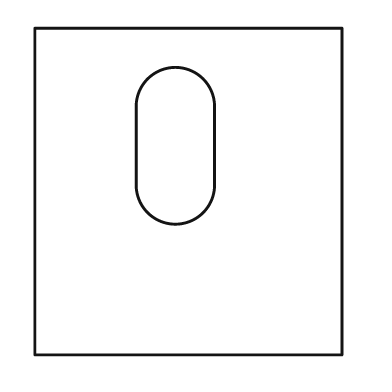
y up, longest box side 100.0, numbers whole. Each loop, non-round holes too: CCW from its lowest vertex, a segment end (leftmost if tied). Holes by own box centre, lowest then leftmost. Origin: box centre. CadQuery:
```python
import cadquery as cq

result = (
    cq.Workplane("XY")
    .moveTo(-47.0, -50.0)
    .lineTo(47.0, -50.0)
    .lineTo(47.0, 50.0)
    .lineTo(-47.0, 50.0)
    .close()
    .moveTo(-16.0, 2.0)
    .threePointArc((-4.0, -10.0), (8.0, 2.0))
    .lineTo(8.0, 26.0)
    .threePointArc((-4.0, 38.0), (-16.0, 26.0))
    .close()
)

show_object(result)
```